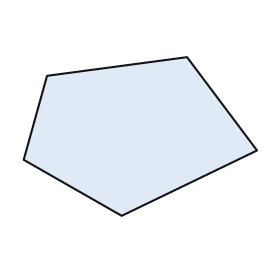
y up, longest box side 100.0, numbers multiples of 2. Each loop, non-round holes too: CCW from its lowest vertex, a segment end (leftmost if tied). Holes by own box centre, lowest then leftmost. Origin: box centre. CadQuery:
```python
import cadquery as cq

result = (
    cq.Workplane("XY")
    .moveTo(-8.0, -34.0)
    .lineTo(50.0, -6.0)
    .lineTo(20.0, 34.0)
    .lineTo(-40.0, 26.0)
    .lineTo(-50.0, -10.0)
    .close()
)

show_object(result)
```